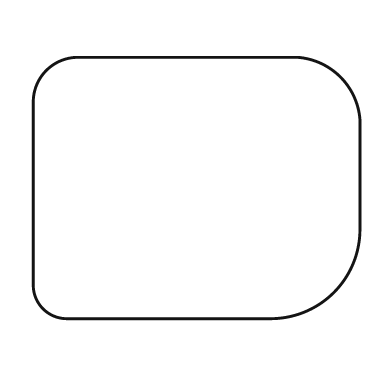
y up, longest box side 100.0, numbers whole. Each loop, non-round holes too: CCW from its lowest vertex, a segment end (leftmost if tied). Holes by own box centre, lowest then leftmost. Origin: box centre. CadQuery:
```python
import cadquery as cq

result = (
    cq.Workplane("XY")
    .moveTo(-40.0, -40.0)
    .lineTo(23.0, -40.0)
    .threePointArc((42.0, -32.0), (50.0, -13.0))
    .lineTo(50.0, 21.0)
    .threePointArc((44.0, 34.0), (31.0, 40.0))
    .lineTo(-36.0, 40.0)
    .threePointArc((-46.0, 36.0), (-50.0, 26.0))
    .lineTo(-50.0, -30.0)
    .threePointArc((-47.0, -37.0), (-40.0, -40.0))
    .close()
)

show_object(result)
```